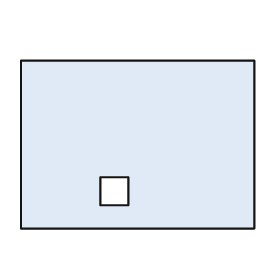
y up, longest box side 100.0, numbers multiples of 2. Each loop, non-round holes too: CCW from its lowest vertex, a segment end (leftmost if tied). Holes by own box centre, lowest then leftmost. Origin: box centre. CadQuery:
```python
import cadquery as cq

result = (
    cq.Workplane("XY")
    .moveTo(-50.0, -36.0)
    .lineTo(50.0, -36.0)
    .lineTo(50.0, 36.0)
    .lineTo(-50.0, 36.0)
    .close()
    .moveTo(-16.0, -26.0)
    .lineTo(-4.0, -26.0)
    .lineTo(-4.0, -14.0)
    .lineTo(-16.0, -14.0)
    .close()
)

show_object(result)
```